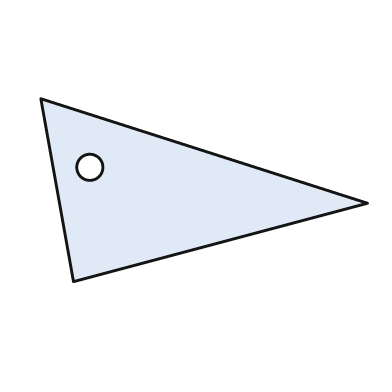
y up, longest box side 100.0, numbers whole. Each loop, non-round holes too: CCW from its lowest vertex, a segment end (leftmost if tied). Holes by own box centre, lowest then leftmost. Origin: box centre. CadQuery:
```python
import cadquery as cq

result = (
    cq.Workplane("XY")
    .moveTo(-40.0, -28.0)
    .lineTo(50.0, -4.0)
    .lineTo(-50.0, 28.0)
    .close()
    .moveTo(-35.0, 7.0)
    .circle(4.0)
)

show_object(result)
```